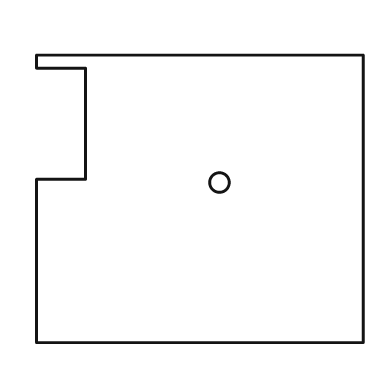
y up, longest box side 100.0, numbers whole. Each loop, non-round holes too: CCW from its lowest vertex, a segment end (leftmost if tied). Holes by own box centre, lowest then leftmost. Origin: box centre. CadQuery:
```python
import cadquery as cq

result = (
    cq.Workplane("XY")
    .moveTo(-50.0, -44.0)
    .lineTo(50.0, -44.0)
    .lineTo(50.0, 44.0)
    .lineTo(-50.0, 44.0)
    .lineTo(-50.0, 40.0)
    .lineTo(-35.0, 40.0)
    .lineTo(-35.0, 6.0)
    .lineTo(-50.0, 6.0)
    .close()
    .moveTo(6.0, 5.0)
    .circle(3.0)
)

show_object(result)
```